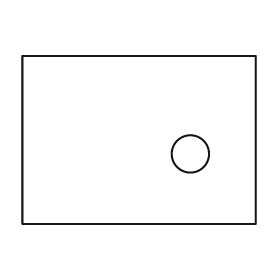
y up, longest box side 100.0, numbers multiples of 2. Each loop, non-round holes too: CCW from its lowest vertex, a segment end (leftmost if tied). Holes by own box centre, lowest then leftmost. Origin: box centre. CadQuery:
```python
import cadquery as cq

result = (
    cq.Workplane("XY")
    .moveTo(-50.0, -36.0)
    .lineTo(50.0, -36.0)
    .lineTo(50.0, 36.0)
    .lineTo(-50.0, 36.0)
    .close()
    .moveTo(22.0, -6.0)
    .circle(8.0)
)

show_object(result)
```